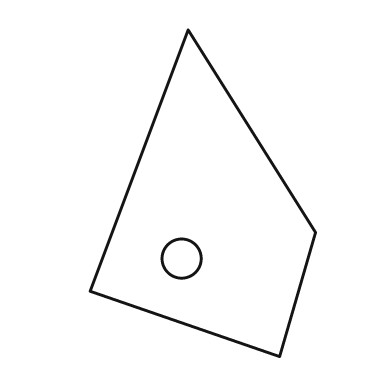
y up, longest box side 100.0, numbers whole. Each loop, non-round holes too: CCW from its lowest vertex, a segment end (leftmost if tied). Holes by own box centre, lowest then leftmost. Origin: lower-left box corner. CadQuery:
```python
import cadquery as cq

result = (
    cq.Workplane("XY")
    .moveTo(58.0, 0.0)
    .lineTo(69.0, 38.0)
    .lineTo(30.0, 100.0)
    .lineTo(0.0, 20.0)
    .close()
    .moveTo(28.0, 30.0)
    .circle(6.0)
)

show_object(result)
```